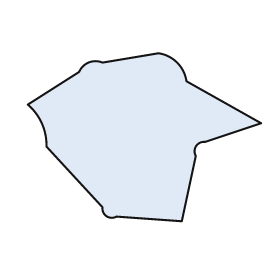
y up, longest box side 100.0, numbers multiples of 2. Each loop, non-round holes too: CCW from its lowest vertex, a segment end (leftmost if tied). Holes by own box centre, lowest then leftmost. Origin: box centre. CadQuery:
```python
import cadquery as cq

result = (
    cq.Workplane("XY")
    .moveTo(16.0, -36.0)
    .lineTo(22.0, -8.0)
    .threePointArc((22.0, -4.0), (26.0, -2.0))
    .lineTo(50.0, 6.0)
    .lineTo(18.0, 24.0)
    .threePointArc((14.0, 32.0), (6.0, 36.0))
    .lineTo(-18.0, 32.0)
    .threePointArc((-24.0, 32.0), (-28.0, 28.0))
    .lineTo(-50.0, 14.0)
    .threePointArc((-44.0, 6.0), (-42.0, -4.0))
    .lineTo(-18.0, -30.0)
    .threePointArc((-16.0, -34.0), (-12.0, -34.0))
    .close()
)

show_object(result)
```